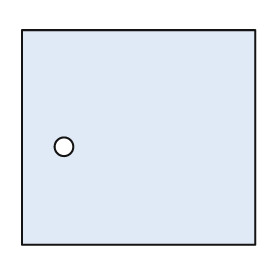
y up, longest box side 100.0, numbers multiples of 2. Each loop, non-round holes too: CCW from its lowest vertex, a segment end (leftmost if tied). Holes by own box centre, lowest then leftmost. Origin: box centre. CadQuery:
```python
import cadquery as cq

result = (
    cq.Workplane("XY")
    .moveTo(-50.0, -46.0)
    .lineTo(50.0, -46.0)
    .lineTo(50.0, 46.0)
    .lineTo(-50.0, 46.0)
    .close()
    .moveTo(-32.0, -4.0)
    .circle(4.0)
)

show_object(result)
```